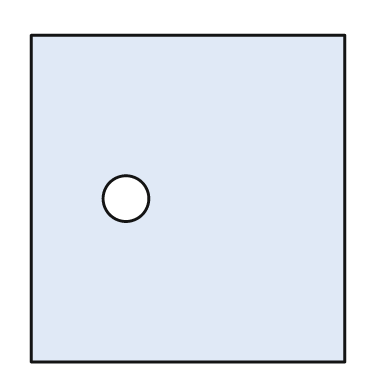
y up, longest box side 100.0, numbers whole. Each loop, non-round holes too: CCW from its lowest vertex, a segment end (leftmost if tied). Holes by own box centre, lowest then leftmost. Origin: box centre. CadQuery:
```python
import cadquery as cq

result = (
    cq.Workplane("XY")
    .moveTo(-48.0, -50.0)
    .lineTo(48.0, -50.0)
    .lineTo(48.0, 50.0)
    .lineTo(-48.0, 50.0)
    .close()
    .moveTo(-19.0, 0.0)
    .circle(7.0)
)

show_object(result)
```